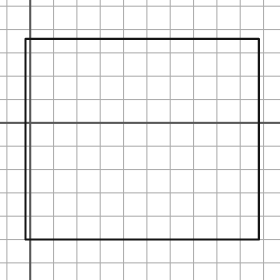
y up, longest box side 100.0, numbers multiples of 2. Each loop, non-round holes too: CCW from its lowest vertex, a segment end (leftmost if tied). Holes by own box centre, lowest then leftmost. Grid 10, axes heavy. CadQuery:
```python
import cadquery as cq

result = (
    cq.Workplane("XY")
    .moveTo(-2.0, -50.0)
    .lineTo(98.0, -50.0)
    .lineTo(98.0, 36.0)
    .lineTo(-2.0, 36.0)
    .close()
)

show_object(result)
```